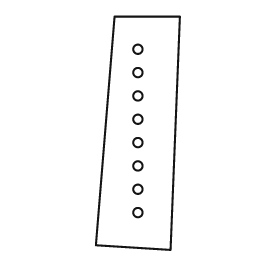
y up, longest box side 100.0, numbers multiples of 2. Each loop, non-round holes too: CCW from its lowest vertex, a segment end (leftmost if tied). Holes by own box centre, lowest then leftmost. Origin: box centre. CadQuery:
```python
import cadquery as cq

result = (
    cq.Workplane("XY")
    .moveTo(14.0, -50.0)
    .lineTo(18.0, 50.0)
    .lineTo(-10.0, 50.0)
    .lineTo(-18.0, -48.0)
    .close()
    .moveTo(0.0, -34.0)
    .circle(2.0)
    .moveTo(0.0, -24.0)
    .circle(2.0)
    .moveTo(0.0, -14.0)
    .circle(2.0)
    .moveTo(0.0, -4.0)
    .circle(2.0)
    .moveTo(0.0, 6.0)
    .circle(2.0)
    .moveTo(0.0, 16.0)
    .circle(2.0)
    .moveTo(0.0, 26.0)
    .circle(2.0)
    .moveTo(0.0, 36.0)
    .circle(2.0)
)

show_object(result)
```